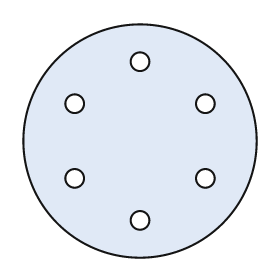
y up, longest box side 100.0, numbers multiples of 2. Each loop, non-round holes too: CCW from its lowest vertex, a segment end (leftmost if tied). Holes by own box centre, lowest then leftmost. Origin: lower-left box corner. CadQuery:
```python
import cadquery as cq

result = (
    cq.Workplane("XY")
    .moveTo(50.0, 50.0)
    .circle(50.0)
    .moveTo(50.0, 16.0)
    .circle(4.0)
    .moveTo(22.0, 34.0)
    .circle(4.0)
    .moveTo(78.0, 34.0)
    .circle(4.0)
    .moveTo(22.0, 66.0)
    .circle(4.0)
    .moveTo(78.0, 66.0)
    .circle(4.0)
    .moveTo(50.0, 84.0)
    .circle(4.0)
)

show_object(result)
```